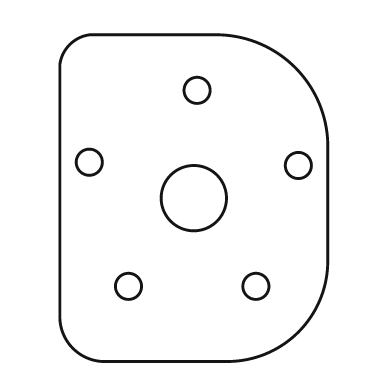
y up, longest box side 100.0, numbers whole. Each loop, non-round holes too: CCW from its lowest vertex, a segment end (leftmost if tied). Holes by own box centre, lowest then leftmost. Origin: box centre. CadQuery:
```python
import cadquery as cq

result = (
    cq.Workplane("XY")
    .moveTo(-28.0, -50.0)
    .lineTo(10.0, -50.0)
    .threePointArc((32.0, -41.0), (41.0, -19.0))
    .lineTo(41.0, 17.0)
    .threePointArc((31.0, 40.0), (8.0, 50.0))
    .lineTo(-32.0, 50.0)
    .threePointArc((-38.0, 47.0), (-41.0, 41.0))
    .lineTo(-41.0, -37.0)
    .threePointArc((-37.0, -46.0), (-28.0, -50.0))
    .close()
    .moveTo(-20.0, -27.0)
    .circle(4.0)
    .moveTo(19.0, -27.0)
    .circle(4.0)
    .moveTo(0.0, 0.0)
    .circle(10.0)
    .moveTo(32.0, 10.0)
    .circle(4.0)
    .moveTo(-32.0, 11.0)
    .circle(4.0)
    .moveTo(1.0, 33.0)
    .circle(4.0)
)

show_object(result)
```